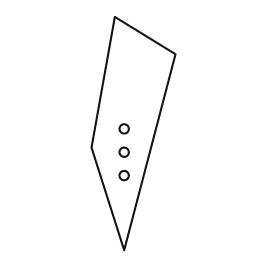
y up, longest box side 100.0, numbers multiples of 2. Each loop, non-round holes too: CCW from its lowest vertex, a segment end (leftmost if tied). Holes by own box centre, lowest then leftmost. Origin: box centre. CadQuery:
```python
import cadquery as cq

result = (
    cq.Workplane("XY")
    .moveTo(-4.0, -50.0)
    .lineTo(18.0, 34.0)
    .lineTo(-8.0, 50.0)
    .lineTo(-18.0, -6.0)
    .close()
    .moveTo(-4.0, -18.0)
    .circle(2.0)
    .moveTo(-4.0, -8.0)
    .circle(2.0)
    .moveTo(-4.0, 2.0)
    .circle(2.0)
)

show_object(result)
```